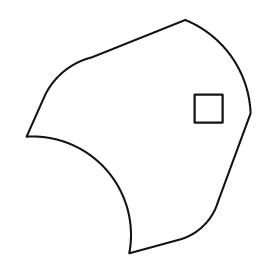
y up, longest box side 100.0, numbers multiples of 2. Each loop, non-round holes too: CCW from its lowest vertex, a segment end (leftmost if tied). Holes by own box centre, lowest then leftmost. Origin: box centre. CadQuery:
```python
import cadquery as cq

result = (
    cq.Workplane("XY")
    .moveTo(-4.0, -50.0)
    .lineTo(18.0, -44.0)
    .threePointArc((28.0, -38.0), (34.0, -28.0))
    .lineTo(48.0, 10.0)
    .threePointArc((40.0, 34.0), (20.0, 50.0))
    .lineTo(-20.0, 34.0)
    .threePointArc((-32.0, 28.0), (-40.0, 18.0))
    .lineTo(-48.0, 0.0)
    .threePointArc((-14.0, -14.0), (-4.0, -50.0))
    .close()
    .moveTo(24.0, 6.0)
    .lineTo(36.0, 6.0)
    .lineTo(36.0, 18.0)
    .lineTo(24.0, 18.0)
    .close()
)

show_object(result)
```